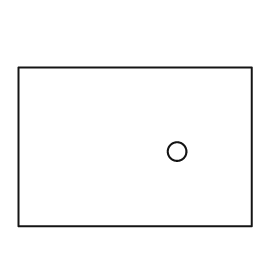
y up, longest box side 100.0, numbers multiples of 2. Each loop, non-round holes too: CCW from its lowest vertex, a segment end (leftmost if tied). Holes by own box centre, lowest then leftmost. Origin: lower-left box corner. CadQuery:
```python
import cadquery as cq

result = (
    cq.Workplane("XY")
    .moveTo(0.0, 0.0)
    .lineTo(100.0, 0.0)
    .lineTo(100.0, 68.0)
    .lineTo(0.0, 68.0)
    .close()
    .moveTo(68.0, 32.0)
    .circle(4.0)
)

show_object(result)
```